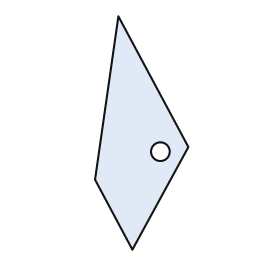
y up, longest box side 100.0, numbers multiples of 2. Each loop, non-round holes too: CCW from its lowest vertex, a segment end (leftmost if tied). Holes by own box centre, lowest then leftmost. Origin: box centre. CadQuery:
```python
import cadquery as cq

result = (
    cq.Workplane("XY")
    .moveTo(-4.0, -50.0)
    .lineTo(20.0, -6.0)
    .lineTo(-10.0, 50.0)
    .lineTo(-20.0, -20.0)
    .close()
    .moveTo(8.0, -8.0)
    .circle(4.0)
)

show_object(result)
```